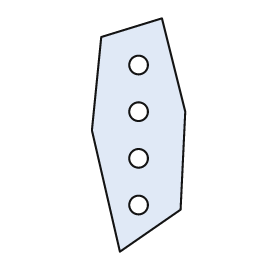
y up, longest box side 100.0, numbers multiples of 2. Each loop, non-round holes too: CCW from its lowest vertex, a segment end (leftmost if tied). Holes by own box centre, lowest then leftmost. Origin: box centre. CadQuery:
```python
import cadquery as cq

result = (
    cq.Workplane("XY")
    .moveTo(-8.0, -50.0)
    .lineTo(18.0, -32.0)
    .lineTo(20.0, 10.0)
    .lineTo(10.0, 50.0)
    .lineTo(-16.0, 42.0)
    .lineTo(-20.0, 2.0)
    .close()
    .moveTo(0.0, -30.0)
    .circle(4.0)
    .moveTo(0.0, -10.0)
    .circle(4.0)
    .moveTo(0.0, 10.0)
    .circle(4.0)
    .moveTo(0.0, 30.0)
    .circle(4.0)
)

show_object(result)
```